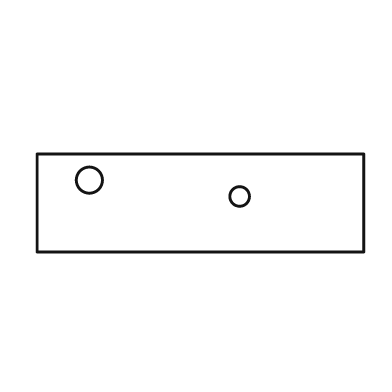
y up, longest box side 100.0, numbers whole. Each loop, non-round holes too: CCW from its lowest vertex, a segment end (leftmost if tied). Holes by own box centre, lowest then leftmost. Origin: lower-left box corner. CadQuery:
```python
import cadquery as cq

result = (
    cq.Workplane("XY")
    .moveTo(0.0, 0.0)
    .lineTo(100.0, 0.0)
    .lineTo(100.0, 30.0)
    .lineTo(0.0, 30.0)
    .close()
    .moveTo(62.0, 17.0)
    .circle(3.0)
    .moveTo(16.0, 22.0)
    .circle(4.0)
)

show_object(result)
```